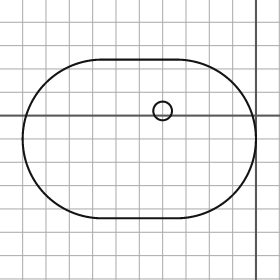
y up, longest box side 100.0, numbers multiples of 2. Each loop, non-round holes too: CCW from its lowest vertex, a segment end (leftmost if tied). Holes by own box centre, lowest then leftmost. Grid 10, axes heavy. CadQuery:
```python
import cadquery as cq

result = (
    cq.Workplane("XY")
    .moveTo(-66.0, -44.0)
    .lineTo(-34.0, -44.0)
    .threePointArc((0.0, -10.0), (-34.0, 24.0))
    .lineTo(-66.0, 24.0)
    .threePointArc((-100.0, -10.0), (-66.0, -44.0))
    .close()
    .moveTo(-40.0, 2.0)
    .circle(4.0)
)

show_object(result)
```